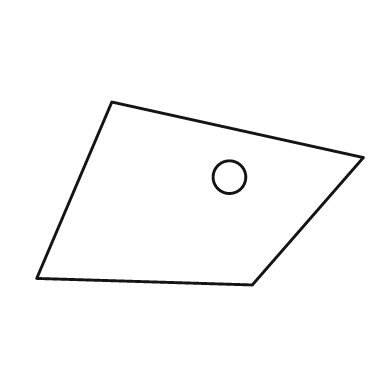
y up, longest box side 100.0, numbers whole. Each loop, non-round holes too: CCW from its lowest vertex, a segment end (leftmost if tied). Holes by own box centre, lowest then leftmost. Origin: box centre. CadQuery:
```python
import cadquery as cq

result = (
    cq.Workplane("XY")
    .moveTo(16.0, -28.0)
    .lineTo(50.0, 11.0)
    .lineTo(-27.0, 28.0)
    .lineTo(-50.0, -26.0)
    .close()
    .moveTo(9.0, 5.0)
    .circle(5.0)
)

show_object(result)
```